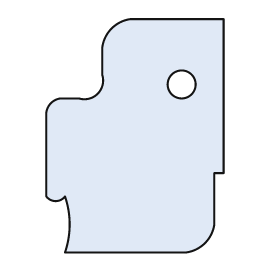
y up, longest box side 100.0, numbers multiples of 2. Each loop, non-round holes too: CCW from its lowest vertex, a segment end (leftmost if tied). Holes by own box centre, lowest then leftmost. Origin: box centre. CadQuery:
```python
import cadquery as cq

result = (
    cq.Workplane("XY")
    .moveTo(-30.0, -50.0)
    .lineTo(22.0, -50.0)
    .threePointArc((30.0, -46.0), (34.0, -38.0))
    .lineTo(34.0, -16.0)
    .lineTo(38.0, -16.0)
    .lineTo(38.0, 50.0)
    .lineTo(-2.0, 50.0)
    .threePointArc((-10.0, 46.0), (-14.0, 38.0))
    .lineTo(-14.0, 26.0)
    .threePointArc((-16.0, 18.0), (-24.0, 16.0))
    .lineTo(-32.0, 16.0)
    .threePointArc((-36.0, 14.0), (-38.0, 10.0))
    .lineTo(-38.0, -26.0)
    .threePointArc((-34.0, -28.0), (-30.0, -26.0))
    .threePointArc((-28.0, -38.0), (-30.0, -50.0))
    .close()
    .moveTo(20.0, 22.0)
    .circle(6.0)
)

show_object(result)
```